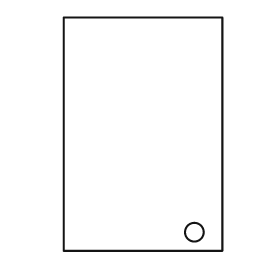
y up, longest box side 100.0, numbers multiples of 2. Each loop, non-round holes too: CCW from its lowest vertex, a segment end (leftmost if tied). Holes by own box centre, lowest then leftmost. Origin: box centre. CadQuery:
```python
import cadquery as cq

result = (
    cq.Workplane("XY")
    .moveTo(-34.0, -50.0)
    .lineTo(34.0, -50.0)
    .lineTo(34.0, 50.0)
    .lineTo(-34.0, 50.0)
    .close()
    .moveTo(22.0, -42.0)
    .circle(4.0)
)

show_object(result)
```